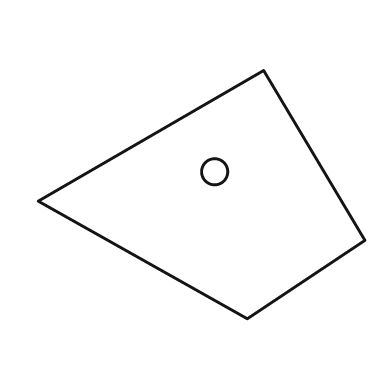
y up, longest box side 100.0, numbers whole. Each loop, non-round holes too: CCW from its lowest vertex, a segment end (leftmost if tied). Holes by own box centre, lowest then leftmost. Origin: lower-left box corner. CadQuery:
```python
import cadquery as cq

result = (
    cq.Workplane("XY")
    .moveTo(64.0, 0.0)
    .lineTo(100.0, 24.0)
    .lineTo(69.0, 76.0)
    .lineTo(0.0, 36.0)
    .close()
    .moveTo(54.0, 45.0)
    .circle(4.0)
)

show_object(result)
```